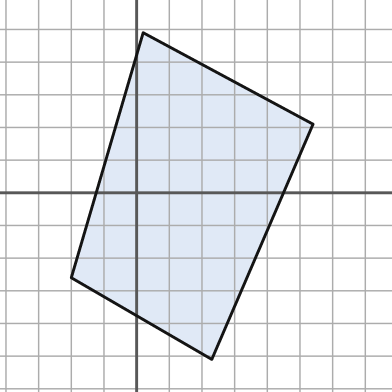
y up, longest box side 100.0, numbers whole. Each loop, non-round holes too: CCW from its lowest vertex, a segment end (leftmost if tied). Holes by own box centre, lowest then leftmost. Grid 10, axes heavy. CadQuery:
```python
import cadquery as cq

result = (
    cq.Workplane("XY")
    .moveTo(23.0, -51.0)
    .lineTo(54.0, 21.0)
    .lineTo(2.0, 49.0)
    .lineTo(-20.0, -26.0)
    .close()
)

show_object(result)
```